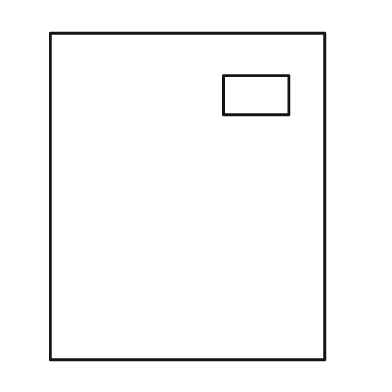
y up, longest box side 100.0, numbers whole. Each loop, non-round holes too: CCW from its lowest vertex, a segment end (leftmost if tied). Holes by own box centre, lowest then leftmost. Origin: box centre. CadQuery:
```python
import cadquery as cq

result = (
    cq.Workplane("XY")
    .moveTo(-42.0, -50.0)
    .lineTo(42.0, -50.0)
    .lineTo(42.0, 50.0)
    .lineTo(-42.0, 50.0)
    .close()
    .moveTo(11.0, 25.0)
    .lineTo(31.0, 25.0)
    .lineTo(31.0, 37.0)
    .lineTo(11.0, 37.0)
    .close()
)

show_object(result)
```